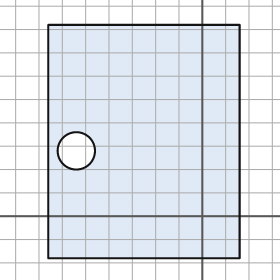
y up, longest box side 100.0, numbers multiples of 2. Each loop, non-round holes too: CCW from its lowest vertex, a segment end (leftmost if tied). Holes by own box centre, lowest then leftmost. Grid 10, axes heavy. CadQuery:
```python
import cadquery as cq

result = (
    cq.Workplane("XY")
    .moveTo(-66.0, -18.0)
    .lineTo(16.0, -18.0)
    .lineTo(16.0, 82.0)
    .lineTo(-66.0, 82.0)
    .close()
    .moveTo(-54.0, 28.0)
    .circle(8.0)
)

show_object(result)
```